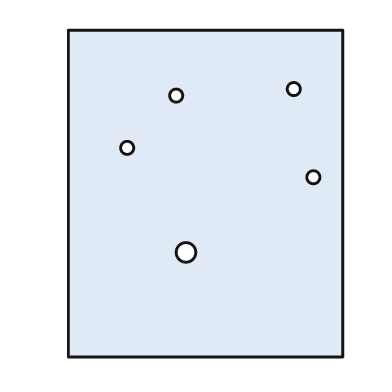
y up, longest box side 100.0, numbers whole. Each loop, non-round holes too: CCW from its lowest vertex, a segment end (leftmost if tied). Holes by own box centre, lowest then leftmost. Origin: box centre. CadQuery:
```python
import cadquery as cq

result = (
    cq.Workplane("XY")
    .moveTo(-42.0, -50.0)
    .lineTo(42.0, -50.0)
    .lineTo(42.0, 50.0)
    .lineTo(-42.0, 50.0)
    .close()
    .moveTo(-6.0, -18.0)
    .circle(3.0)
    .moveTo(33.0, 5.0)
    .circle(2.0)
    .moveTo(-24.0, 14.0)
    .circle(2.0)
    .moveTo(-9.0, 30.0)
    .circle(2.0)
    .moveTo(27.0, 32.0)
    .circle(2.0)
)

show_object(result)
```